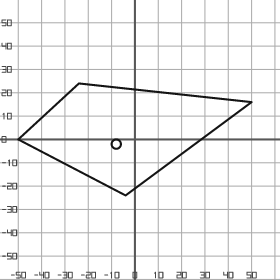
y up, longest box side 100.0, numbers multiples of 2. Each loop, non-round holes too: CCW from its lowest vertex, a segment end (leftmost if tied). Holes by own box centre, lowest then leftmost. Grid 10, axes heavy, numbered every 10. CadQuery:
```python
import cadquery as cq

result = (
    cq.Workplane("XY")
    .moveTo(-4.0, -24.0)
    .lineTo(50.0, 16.0)
    .lineTo(-24.0, 24.0)
    .lineTo(-50.0, 0.0)
    .close()
    .moveTo(-8.0, -2.0)
    .circle(2.0)
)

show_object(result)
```